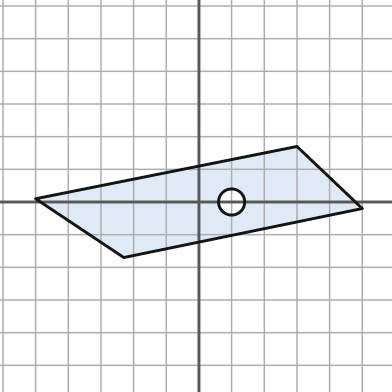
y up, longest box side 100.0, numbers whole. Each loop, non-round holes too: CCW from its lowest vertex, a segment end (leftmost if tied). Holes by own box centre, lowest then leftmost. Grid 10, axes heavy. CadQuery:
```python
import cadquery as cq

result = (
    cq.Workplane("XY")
    .moveTo(-23.0, -17.0)
    .lineTo(50.0, -2.0)
    .lineTo(30.0, 17.0)
    .lineTo(-50.0, 1.0)
    .close()
    .moveTo(10.0, 0.0)
    .circle(4.0)
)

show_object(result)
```